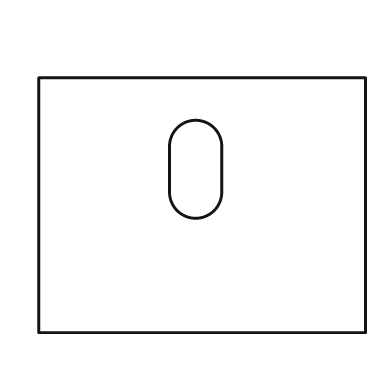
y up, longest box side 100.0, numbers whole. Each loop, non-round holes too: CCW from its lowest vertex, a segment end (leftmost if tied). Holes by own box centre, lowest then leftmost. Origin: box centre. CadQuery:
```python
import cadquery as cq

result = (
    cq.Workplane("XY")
    .moveTo(-50.0, -39.0)
    .lineTo(50.0, -39.0)
    .lineTo(50.0, 39.0)
    .lineTo(-50.0, 39.0)
    .close()
    .moveTo(-10.0, 4.0)
    .threePointArc((-2.0, -4.0), (6.0, 4.0))
    .lineTo(6.0, 18.0)
    .threePointArc((-2.0, 26.0), (-10.0, 18.0))
    .close()
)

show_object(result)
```